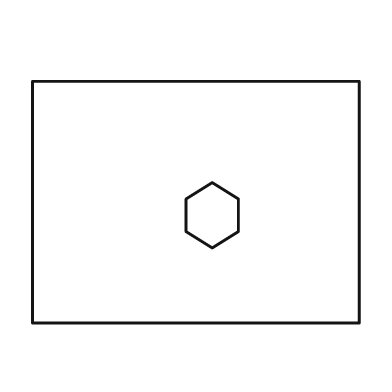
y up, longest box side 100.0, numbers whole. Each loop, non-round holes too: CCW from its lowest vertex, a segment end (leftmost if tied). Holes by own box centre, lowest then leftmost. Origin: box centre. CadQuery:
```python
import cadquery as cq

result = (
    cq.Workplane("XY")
    .moveTo(-50.0, -37.0)
    .lineTo(50.0, -37.0)
    .lineTo(50.0, 37.0)
    .lineTo(-50.0, 37.0)
    .close()
    .moveTo(5.0, -14.0)
    .lineTo(13.0, -9.0)
    .lineTo(13.0, 1.0)
    .lineTo(5.0, 6.0)
    .lineTo(-3.0, 1.0)
    .lineTo(-3.0, -9.0)
    .close()
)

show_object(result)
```